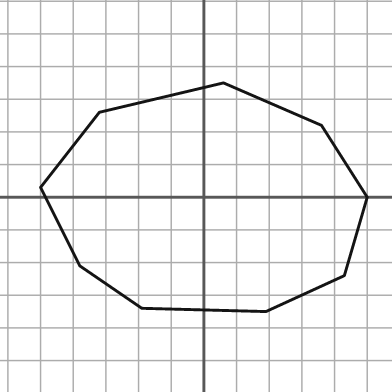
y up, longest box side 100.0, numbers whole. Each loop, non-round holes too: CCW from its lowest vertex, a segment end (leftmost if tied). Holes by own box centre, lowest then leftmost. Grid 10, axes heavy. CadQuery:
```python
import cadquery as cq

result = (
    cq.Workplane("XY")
    .moveTo(19.0, -35.0)
    .lineTo(43.0, -24.0)
    .lineTo(50.0, 0.0)
    .lineTo(36.0, 22.0)
    .lineTo(6.0, 35.0)
    .lineTo(-32.0, 26.0)
    .lineTo(-50.0, 3.0)
    .lineTo(-38.0, -21.0)
    .lineTo(-19.0, -34.0)
    .close()
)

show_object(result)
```